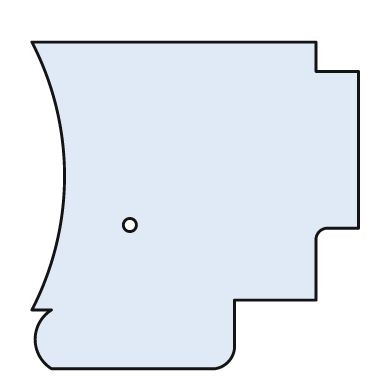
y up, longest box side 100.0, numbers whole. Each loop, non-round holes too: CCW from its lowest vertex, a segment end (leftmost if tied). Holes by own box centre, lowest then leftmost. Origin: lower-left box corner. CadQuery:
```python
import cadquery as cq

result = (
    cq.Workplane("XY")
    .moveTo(6.0, 0.0)
    .lineTo(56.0, 0.0)
    .threePointArc((60.0, 2.0), (62.0, 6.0))
    .lineTo(62.0, 21.0)
    .lineTo(87.0, 21.0)
    .lineTo(87.0, 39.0)
    .threePointArc((88.0, 42.0), (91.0, 43.0))
    .lineTo(100.0, 43.0)
    .lineTo(100.0, 91.0)
    .lineTo(87.0, 91.0)
    .lineTo(87.0, 100.0)
    .lineTo(0.0, 100.0)
    .threePointArc((10.0, 59.0), (0.0, 18.0))
    .lineTo(6.0, 18.0)
    .threePointArc((1.0, 9.0), (6.0, 0.0))
    .close()
    .moveTo(30.0, 44.0)
    .circle(2.0)
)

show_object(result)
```